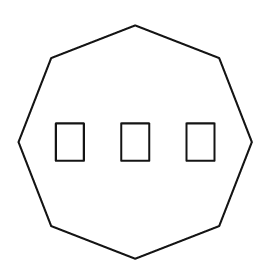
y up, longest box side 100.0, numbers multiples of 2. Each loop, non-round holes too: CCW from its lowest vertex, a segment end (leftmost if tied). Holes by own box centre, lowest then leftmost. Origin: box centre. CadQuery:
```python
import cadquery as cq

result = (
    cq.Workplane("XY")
    .moveTo(0.0, -50.0)
    .lineTo(36.0, -36.0)
    .lineTo(50.0, 0.0)
    .lineTo(36.0, 36.0)
    .lineTo(0.0, 50.0)
    .lineTo(-36.0, 36.0)
    .lineTo(-50.0, 0.0)
    .lineTo(-36.0, -36.0)
    .close()
    .moveTo(-34.0, -8.0)
    .lineTo(-22.0, -8.0)
    .lineTo(-22.0, 8.0)
    .lineTo(-34.0, 8.0)
    .close()
    .moveTo(-6.0, -8.0)
    .lineTo(6.0, -8.0)
    .lineTo(6.0, 8.0)
    .lineTo(-6.0, 8.0)
    .close()
    .moveTo(22.0, -8.0)
    .lineTo(34.0, -8.0)
    .lineTo(34.0, 8.0)
    .lineTo(22.0, 8.0)
    .close()
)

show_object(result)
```